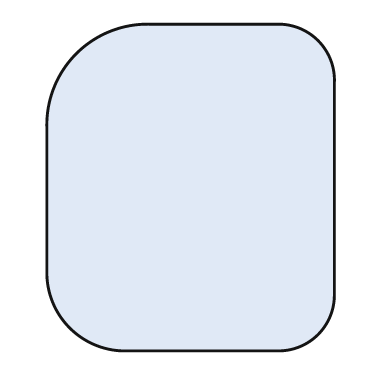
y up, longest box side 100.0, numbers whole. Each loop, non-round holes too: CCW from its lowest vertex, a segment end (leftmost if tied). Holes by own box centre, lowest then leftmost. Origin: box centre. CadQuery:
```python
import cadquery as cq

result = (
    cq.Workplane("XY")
    .moveTo(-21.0, -50.0)
    .lineTo(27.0, -50.0)
    .threePointArc((39.0, -45.0), (44.0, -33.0))
    .lineTo(44.0, 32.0)
    .threePointArc((39.0, 45.0), (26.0, 50.0))
    .lineTo(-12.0, 50.0)
    .threePointArc((-35.0, 41.0), (-44.0, 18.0))
    .lineTo(-44.0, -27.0)
    .threePointArc((-37.0, -43.0), (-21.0, -50.0))
    .close()
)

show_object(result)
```